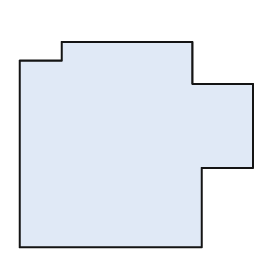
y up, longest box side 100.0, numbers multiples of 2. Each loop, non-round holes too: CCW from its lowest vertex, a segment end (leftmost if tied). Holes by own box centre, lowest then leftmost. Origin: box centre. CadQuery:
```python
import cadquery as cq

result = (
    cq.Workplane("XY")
    .moveTo(-50.0, -44.0)
    .lineTo(28.0, -44.0)
    .lineTo(28.0, -10.0)
    .lineTo(50.0, -10.0)
    .lineTo(50.0, 26.0)
    .lineTo(24.0, 26.0)
    .lineTo(24.0, 44.0)
    .lineTo(-32.0, 44.0)
    .lineTo(-32.0, 36.0)
    .lineTo(-50.0, 36.0)
    .close()
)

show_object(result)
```